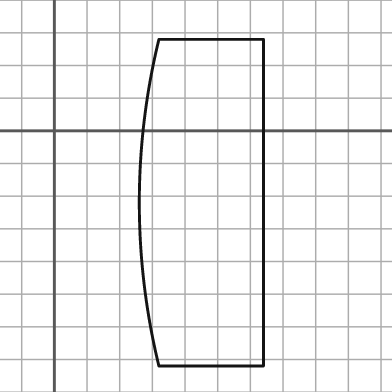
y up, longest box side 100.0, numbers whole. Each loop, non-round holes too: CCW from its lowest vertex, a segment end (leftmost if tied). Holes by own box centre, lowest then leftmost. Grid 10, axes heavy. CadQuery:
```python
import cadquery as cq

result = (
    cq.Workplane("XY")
    .moveTo(32.0, -72.0)
    .lineTo(64.0, -72.0)
    .lineTo(64.0, 28.0)
    .lineTo(32.0, 28.0)
    .threePointArc((26.0, -22.0), (32.0, -72.0))
    .close()
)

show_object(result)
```